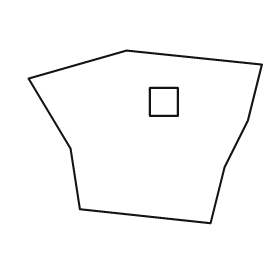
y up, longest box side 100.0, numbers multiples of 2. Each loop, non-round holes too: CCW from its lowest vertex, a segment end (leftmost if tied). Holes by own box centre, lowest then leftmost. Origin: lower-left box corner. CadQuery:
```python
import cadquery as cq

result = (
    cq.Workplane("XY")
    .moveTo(78.0, 0.0)
    .lineTo(84.0, 24.0)
    .lineTo(94.0, 44.0)
    .lineTo(100.0, 68.0)
    .lineTo(42.0, 74.0)
    .lineTo(0.0, 62.0)
    .lineTo(18.0, 32.0)
    .lineTo(22.0, 6.0)
    .close()
    .moveTo(52.0, 46.0)
    .lineTo(64.0, 46.0)
    .lineTo(64.0, 58.0)
    .lineTo(52.0, 58.0)
    .close()
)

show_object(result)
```